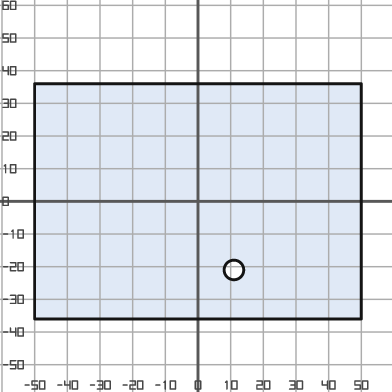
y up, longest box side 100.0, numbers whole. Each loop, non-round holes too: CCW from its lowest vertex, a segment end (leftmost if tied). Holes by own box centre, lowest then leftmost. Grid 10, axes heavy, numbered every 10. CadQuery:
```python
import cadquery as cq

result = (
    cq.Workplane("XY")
    .moveTo(-50.0, -36.0)
    .lineTo(50.0, -36.0)
    .lineTo(50.0, 36.0)
    .lineTo(-50.0, 36.0)
    .close()
    .moveTo(11.0, -21.0)
    .circle(3.0)
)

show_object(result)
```